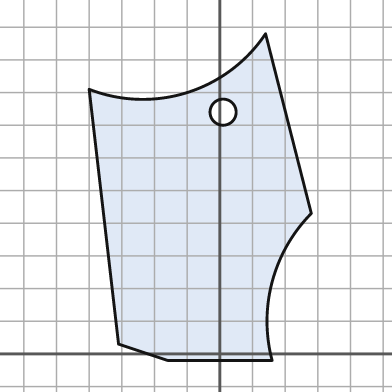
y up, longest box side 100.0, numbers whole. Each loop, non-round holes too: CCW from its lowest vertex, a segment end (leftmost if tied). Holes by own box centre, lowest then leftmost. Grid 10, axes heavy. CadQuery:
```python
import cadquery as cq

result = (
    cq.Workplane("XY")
    .moveTo(-16.0, -2.0)
    .lineTo(16.0, -2.0)
    .threePointArc((16.0, 22.0), (28.0, 43.0))
    .lineTo(14.0, 98.0)
    .threePointArc((-10.0, 80.0), (-40.0, 81.0))
    .lineTo(-31.0, 3.0)
    .close()
    .moveTo(1.0, 74.0)
    .circle(4.0)
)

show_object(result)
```